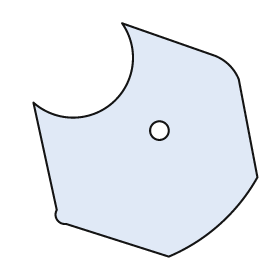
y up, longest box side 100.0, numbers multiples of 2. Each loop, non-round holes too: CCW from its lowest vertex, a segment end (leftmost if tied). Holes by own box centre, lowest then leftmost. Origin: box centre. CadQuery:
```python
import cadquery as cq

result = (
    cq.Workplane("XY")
    .moveTo(10.0, -50.0)
    .threePointArc((32.0, -36.0), (48.0, -16.0))
    .lineTo(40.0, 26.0)
    .threePointArc((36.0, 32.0), (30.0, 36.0))
    .lineTo(-10.0, 50.0)
    .threePointArc((-14.0, 16.0), (-48.0, 16.0))
    .lineTo(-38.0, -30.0)
    .threePointArc((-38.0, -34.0), (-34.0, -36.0))
    .close()
    .moveTo(6.0, 4.0)
    .circle(4.0)
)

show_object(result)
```